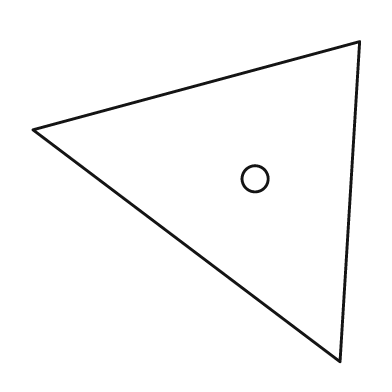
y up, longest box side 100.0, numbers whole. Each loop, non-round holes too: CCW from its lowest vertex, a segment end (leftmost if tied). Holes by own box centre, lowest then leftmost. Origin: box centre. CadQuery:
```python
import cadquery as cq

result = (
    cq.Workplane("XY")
    .moveTo(44.0, -49.0)
    .lineTo(50.0, 49.0)
    .lineTo(-50.0, 22.0)
    .close()
    .moveTo(18.0, 7.0)
    .circle(4.0)
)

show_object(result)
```